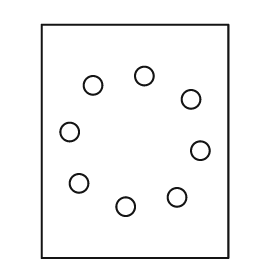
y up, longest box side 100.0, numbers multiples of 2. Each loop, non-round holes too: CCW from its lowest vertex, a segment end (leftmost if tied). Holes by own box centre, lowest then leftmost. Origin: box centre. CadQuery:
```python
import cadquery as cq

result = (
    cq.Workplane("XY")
    .moveTo(-40.0, -50.0)
    .lineTo(40.0, -50.0)
    .lineTo(40.0, 50.0)
    .lineTo(-40.0, 50.0)
    .close()
    .moveTo(-4.0, -28.0)
    .circle(4.0)
    .moveTo(18.0, -24.0)
    .circle(4.0)
    .moveTo(-24.0, -18.0)
    .circle(4.0)
    .moveTo(28.0, -4.0)
    .circle(4.0)
    .moveTo(-28.0, 4.0)
    .circle(4.0)
    .moveTo(24.0, 18.0)
    .circle(4.0)
    .moveTo(-18.0, 24.0)
    .circle(4.0)
    .moveTo(4.0, 28.0)
    .circle(4.0)
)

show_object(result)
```